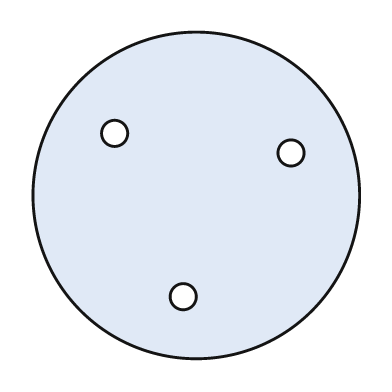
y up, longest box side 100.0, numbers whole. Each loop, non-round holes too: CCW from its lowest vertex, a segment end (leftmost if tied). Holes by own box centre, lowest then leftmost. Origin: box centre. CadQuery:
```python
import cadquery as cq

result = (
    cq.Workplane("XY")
    .moveTo(0.0, 0.0)
    .circle(50.0)
    .moveTo(-4.0, -31.0)
    .circle(4.0)
    .moveTo(29.0, 13.0)
    .circle(4.0)
    .moveTo(-25.0, 19.0)
    .circle(4.0)
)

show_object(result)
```